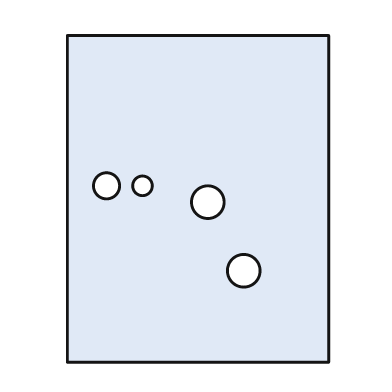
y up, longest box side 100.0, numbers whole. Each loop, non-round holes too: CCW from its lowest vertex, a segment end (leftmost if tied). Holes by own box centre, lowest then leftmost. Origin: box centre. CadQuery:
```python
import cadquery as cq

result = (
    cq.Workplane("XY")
    .moveTo(-40.0, -50.0)
    .lineTo(40.0, -50.0)
    .lineTo(40.0, 50.0)
    .lineTo(-40.0, 50.0)
    .close()
    .moveTo(14.0, -22.0)
    .circle(5.0)
    .moveTo(3.0, -1.0)
    .circle(5.0)
    .moveTo(-28.0, 4.0)
    .circle(4.0)
    .moveTo(-17.0, 4.0)
    .circle(3.0)
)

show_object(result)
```